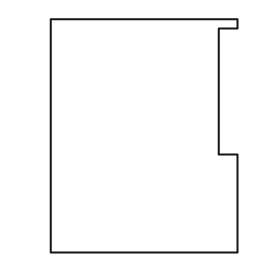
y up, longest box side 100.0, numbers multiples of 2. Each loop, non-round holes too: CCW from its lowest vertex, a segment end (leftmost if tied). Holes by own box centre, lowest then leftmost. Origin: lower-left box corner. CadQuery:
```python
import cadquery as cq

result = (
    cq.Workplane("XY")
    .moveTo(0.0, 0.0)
    .lineTo(80.0, 0.0)
    .lineTo(80.0, 42.0)
    .lineTo(72.0, 42.0)
    .lineTo(72.0, 96.0)
    .lineTo(80.0, 96.0)
    .lineTo(80.0, 100.0)
    .lineTo(0.0, 100.0)
    .close()
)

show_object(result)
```